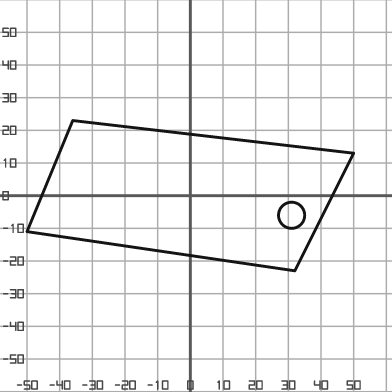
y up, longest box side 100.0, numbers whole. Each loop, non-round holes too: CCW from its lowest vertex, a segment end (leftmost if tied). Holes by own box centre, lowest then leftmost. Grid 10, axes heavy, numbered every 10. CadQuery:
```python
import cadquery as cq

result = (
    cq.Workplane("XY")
    .moveTo(32.0, -23.0)
    .lineTo(50.0, 13.0)
    .lineTo(-36.0, 23.0)
    .lineTo(-50.0, -11.0)
    .close()
    .moveTo(31.0, -6.0)
    .circle(4.0)
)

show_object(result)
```